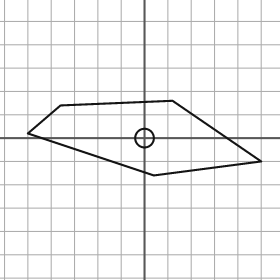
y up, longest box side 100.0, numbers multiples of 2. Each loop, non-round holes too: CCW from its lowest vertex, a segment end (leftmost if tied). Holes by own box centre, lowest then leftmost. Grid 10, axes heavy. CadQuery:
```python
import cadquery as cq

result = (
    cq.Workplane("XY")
    .moveTo(4.0, -16.0)
    .lineTo(50.0, -10.0)
    .lineTo(12.0, 16.0)
    .lineTo(-36.0, 14.0)
    .lineTo(-50.0, 2.0)
    .close()
    .moveTo(0.0, 0.0)
    .circle(4.0)
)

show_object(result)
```